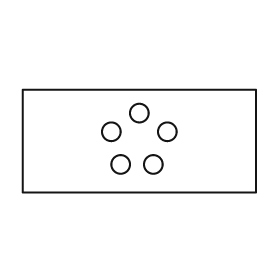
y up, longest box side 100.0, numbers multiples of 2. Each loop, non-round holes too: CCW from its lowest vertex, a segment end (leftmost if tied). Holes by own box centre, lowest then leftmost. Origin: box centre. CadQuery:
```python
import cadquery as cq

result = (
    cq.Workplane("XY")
    .moveTo(-50.0, -22.0)
    .lineTo(50.0, -22.0)
    .lineTo(50.0, 22.0)
    .lineTo(-50.0, 22.0)
    .close()
    .moveTo(-8.0, -10.0)
    .circle(4.0)
    .moveTo(6.0, -10.0)
    .circle(4.0)
    .moveTo(-12.0, 4.0)
    .circle(4.0)
    .moveTo(12.0, 4.0)
    .circle(4.0)
    .moveTo(0.0, 12.0)
    .circle(4.0)
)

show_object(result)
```